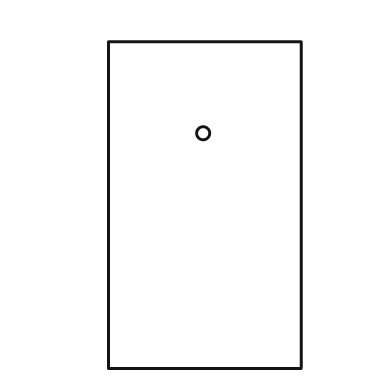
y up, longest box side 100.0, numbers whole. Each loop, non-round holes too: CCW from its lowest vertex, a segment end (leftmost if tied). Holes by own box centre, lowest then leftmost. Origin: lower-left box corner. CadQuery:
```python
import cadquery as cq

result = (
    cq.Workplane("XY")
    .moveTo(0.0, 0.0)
    .lineTo(59.0, 0.0)
    .lineTo(59.0, 100.0)
    .lineTo(0.0, 100.0)
    .close()
    .moveTo(29.0, 72.0)
    .circle(2.0)
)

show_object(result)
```